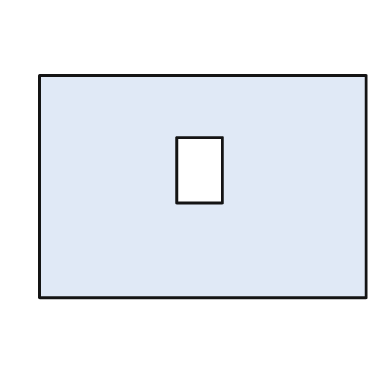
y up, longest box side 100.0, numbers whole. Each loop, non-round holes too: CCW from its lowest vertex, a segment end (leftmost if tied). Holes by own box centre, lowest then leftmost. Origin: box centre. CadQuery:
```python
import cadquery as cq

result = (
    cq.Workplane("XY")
    .moveTo(-50.0, -34.0)
    .lineTo(50.0, -34.0)
    .lineTo(50.0, 34.0)
    .lineTo(-50.0, 34.0)
    .close()
    .moveTo(-8.0, -5.0)
    .lineTo(6.0, -5.0)
    .lineTo(6.0, 15.0)
    .lineTo(-8.0, 15.0)
    .close()
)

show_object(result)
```